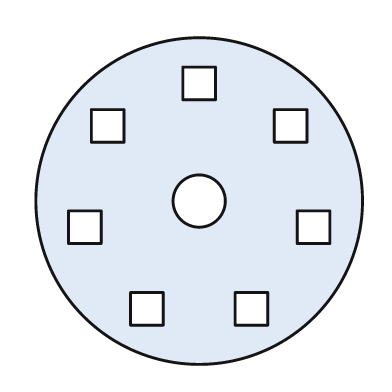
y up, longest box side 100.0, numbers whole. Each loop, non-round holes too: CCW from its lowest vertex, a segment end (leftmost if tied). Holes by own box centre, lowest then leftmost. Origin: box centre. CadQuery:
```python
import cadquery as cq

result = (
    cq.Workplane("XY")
    .moveTo(0.0, 0.0)
    .circle(50.0)
    .moveTo(-21.0, -38.0)
    .lineTo(-11.0, -38.0)
    .lineTo(-11.0, -28.0)
    .lineTo(-21.0, -28.0)
    .close()
    .moveTo(11.0, -38.0)
    .lineTo(21.0, -38.0)
    .lineTo(21.0, -28.0)
    .lineTo(11.0, -28.0)
    .close()
    .moveTo(-40.0, -13.0)
    .lineTo(-30.0, -13.0)
    .lineTo(-30.0, -3.0)
    .lineTo(-40.0, -3.0)
    .close()
    .moveTo(30.0, -13.0)
    .lineTo(40.0, -13.0)
    .lineTo(40.0, -3.0)
    .lineTo(30.0, -3.0)
    .close()
    .moveTo(0.0, 0.0)
    .circle(8.0)
    .moveTo(-33.0, 18.0)
    .lineTo(-23.0, 18.0)
    .lineTo(-23.0, 28.0)
    .lineTo(-33.0, 28.0)
    .close()
    .moveTo(23.0, 18.0)
    .lineTo(33.0, 18.0)
    .lineTo(33.0, 28.0)
    .lineTo(23.0, 28.0)
    .close()
    .moveTo(-5.0, 31.0)
    .lineTo(5.0, 31.0)
    .lineTo(5.0, 41.0)
    .lineTo(-5.0, 41.0)
    .close()
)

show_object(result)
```